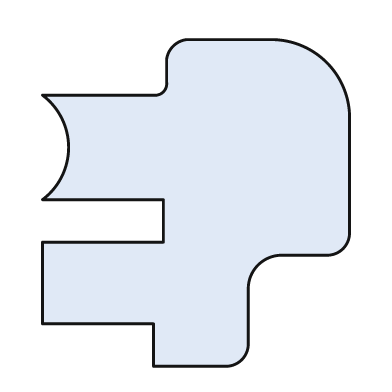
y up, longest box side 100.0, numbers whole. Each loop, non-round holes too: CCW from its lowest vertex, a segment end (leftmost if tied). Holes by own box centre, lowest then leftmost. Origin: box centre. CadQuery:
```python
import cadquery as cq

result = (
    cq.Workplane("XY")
    .moveTo(-13.0, -50.0)
    .lineTo(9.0, -50.0)
    .threePointArc((14.0, -48.0), (16.0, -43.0))
    .lineTo(16.0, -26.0)
    .threePointArc((19.0, -19.0), (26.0, -16.0))
    .lineTo(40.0, -16.0)
    .threePointArc((45.0, -14.0), (47.0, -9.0))
    .lineTo(47.0, 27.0)
    .threePointArc((40.0, 43.0), (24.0, 50.0))
    .lineTo(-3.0, 50.0)
    .threePointArc((-7.0, 48.0), (-9.0, 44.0))
    .lineTo(-9.0, 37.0)
    .threePointArc((-10.0, 34.0), (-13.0, 33.0))
    .lineTo(-47.0, 33.0)
    .threePointArc((-39.0, 17.0), (-47.0, 1.0))
    .lineTo(-10.0, 1.0)
    .lineTo(-10.0, -12.0)
    .lineTo(-47.0, -12.0)
    .lineTo(-47.0, -37.0)
    .lineTo(-13.0, -37.0)
    .close()
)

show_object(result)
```